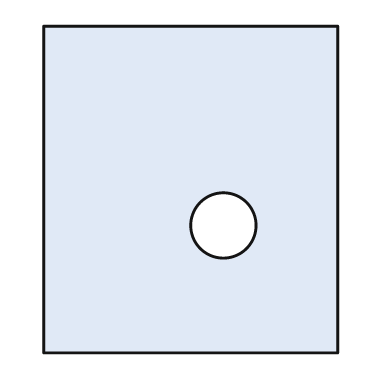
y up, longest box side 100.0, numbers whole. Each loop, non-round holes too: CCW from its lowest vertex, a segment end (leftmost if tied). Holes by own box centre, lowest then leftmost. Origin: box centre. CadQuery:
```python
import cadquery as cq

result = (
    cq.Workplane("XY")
    .moveTo(-45.0, -50.0)
    .lineTo(45.0, -50.0)
    .lineTo(45.0, 50.0)
    .lineTo(-45.0, 50.0)
    .close()
    .moveTo(10.0, -11.0)
    .circle(10.0)
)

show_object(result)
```